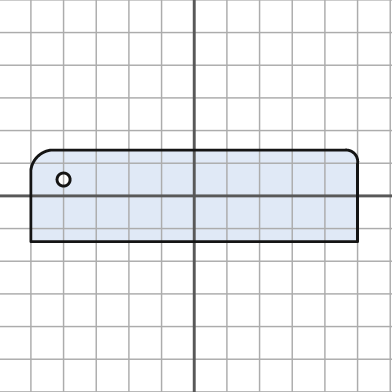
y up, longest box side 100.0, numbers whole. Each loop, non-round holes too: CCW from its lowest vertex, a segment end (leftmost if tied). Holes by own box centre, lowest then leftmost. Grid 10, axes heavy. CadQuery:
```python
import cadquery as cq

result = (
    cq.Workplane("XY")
    .moveTo(-50.0, -14.0)
    .lineTo(50.0, -14.0)
    .lineTo(50.0, 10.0)
    .threePointArc((49.0, 13.0), (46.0, 14.0))
    .lineTo(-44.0, 14.0)
    .threePointArc((-48.0, 12.0), (-50.0, 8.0))
    .close()
    .moveTo(-40.0, 5.0)
    .circle(2.0)
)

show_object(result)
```